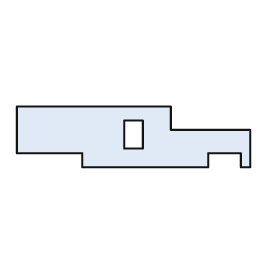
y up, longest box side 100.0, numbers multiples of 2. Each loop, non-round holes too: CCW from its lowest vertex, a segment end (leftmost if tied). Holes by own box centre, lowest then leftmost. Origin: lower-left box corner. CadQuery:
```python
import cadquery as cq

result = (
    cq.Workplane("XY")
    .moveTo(28.0, 0.0)
    .lineTo(82.0, 0.0)
    .lineTo(82.0, 6.0)
    .lineTo(96.0, 6.0)
    .lineTo(96.0, 0.0)
    .lineTo(100.0, 0.0)
    .lineTo(100.0, 16.0)
    .lineTo(66.0, 16.0)
    .lineTo(66.0, 26.0)
    .lineTo(0.0, 26.0)
    .lineTo(0.0, 6.0)
    .lineTo(28.0, 6.0)
    .close()
    .moveTo(46.0, 8.0)
    .lineTo(54.0, 8.0)
    .lineTo(54.0, 20.0)
    .lineTo(46.0, 20.0)
    .close()
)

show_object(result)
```